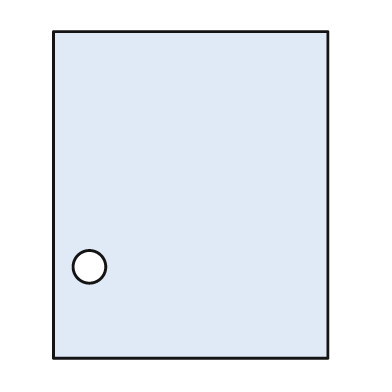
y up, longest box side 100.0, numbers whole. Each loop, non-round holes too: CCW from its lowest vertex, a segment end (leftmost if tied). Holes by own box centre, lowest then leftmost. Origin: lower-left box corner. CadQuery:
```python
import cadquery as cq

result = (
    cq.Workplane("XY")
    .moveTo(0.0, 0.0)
    .lineTo(84.0, 0.0)
    .lineTo(84.0, 100.0)
    .lineTo(0.0, 100.0)
    .close()
    .moveTo(11.0, 28.0)
    .circle(5.0)
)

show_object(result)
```